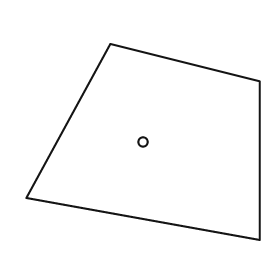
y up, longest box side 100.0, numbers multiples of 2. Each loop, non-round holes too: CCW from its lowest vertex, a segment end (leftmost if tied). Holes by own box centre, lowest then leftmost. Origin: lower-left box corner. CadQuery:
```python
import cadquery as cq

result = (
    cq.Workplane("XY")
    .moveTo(100.0, 0.0)
    .lineTo(100.0, 68.0)
    .lineTo(36.0, 84.0)
    .lineTo(0.0, 18.0)
    .close()
    .moveTo(50.0, 42.0)
    .circle(2.0)
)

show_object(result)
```